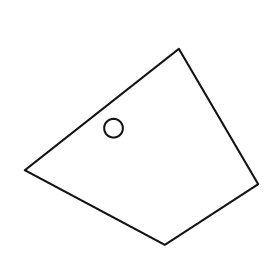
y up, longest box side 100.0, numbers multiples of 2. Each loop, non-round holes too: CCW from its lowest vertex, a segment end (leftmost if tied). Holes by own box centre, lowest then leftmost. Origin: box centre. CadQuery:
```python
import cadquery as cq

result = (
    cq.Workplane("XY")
    .moveTo(10.0, -42.0)
    .lineTo(50.0, -16.0)
    .lineTo(16.0, 42.0)
    .lineTo(-50.0, -10.0)
    .close()
    .moveTo(-12.0, 8.0)
    .circle(4.0)
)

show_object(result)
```